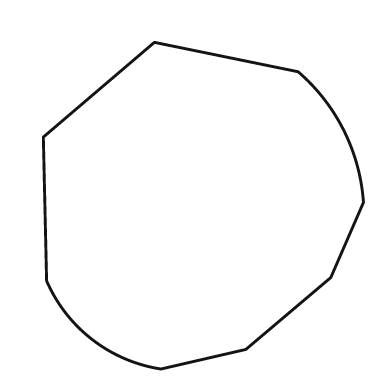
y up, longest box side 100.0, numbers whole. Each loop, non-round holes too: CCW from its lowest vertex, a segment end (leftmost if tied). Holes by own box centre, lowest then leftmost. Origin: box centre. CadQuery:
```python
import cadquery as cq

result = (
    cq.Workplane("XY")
    .moveTo(-13.0, -50.0)
    .lineTo(13.0, -44.0)
    .lineTo(39.0, -22.0)
    .lineTo(49.0, 1.0)
    .threePointArc((43.0, 23.0), (29.0, 41.0))
    .lineTo(-15.0, 50.0)
    .lineTo(-49.0, 21.0)
    .lineTo(-48.0, -23.0)
    .threePointArc((-34.0, -41.0), (-13.0, -50.0))
    .close()
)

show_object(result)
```